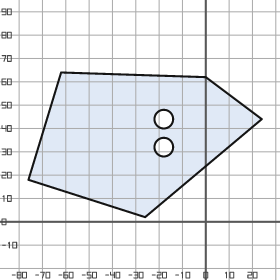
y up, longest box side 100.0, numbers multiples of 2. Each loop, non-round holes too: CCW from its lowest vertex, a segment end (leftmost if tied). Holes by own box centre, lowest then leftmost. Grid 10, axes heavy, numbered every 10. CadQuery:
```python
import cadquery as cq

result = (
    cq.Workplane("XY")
    .moveTo(-26.0, 2.0)
    .lineTo(24.0, 44.0)
    .lineTo(0.0, 62.0)
    .lineTo(-62.0, 64.0)
    .lineTo(-76.0, 18.0)
    .close()
    .moveTo(-18.0, 32.0)
    .circle(4.0)
    .moveTo(-18.0, 44.0)
    .circle(4.0)
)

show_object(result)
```